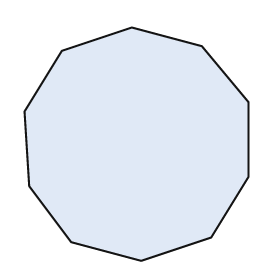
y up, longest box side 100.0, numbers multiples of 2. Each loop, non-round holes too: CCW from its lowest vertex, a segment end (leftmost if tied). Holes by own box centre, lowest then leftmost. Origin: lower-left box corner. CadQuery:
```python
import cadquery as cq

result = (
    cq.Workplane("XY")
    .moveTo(50.0, 0.0)
    .lineTo(80.0, 10.0)
    .lineTo(96.0, 36.0)
    .lineTo(96.0, 68.0)
    .lineTo(76.0, 92.0)
    .lineTo(46.0, 100.0)
    .lineTo(16.0, 90.0)
    .lineTo(0.0, 64.0)
    .lineTo(2.0, 32.0)
    .lineTo(20.0, 8.0)
    .close()
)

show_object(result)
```